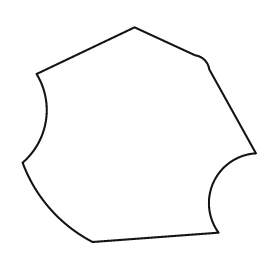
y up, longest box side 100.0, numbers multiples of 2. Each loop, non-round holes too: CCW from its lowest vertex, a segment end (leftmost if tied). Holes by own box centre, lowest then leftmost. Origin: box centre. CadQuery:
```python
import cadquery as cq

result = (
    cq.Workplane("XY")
    .moveTo(-20.0, -46.0)
    .lineTo(34.0, -42.0)
    .threePointArc((32.0, -20.0), (50.0, -8.0))
    .lineTo(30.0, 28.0)
    .threePointArc((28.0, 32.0), (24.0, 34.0))
    .lineTo(-2.0, 46.0)
    .lineTo(-44.0, 26.0)
    .threePointArc((-40.0, 6.0), (-50.0, -12.0))
    .threePointArc((-38.0, -32.0), (-20.0, -46.0))
    .close()
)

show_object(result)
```